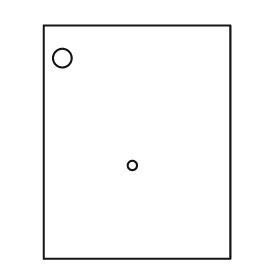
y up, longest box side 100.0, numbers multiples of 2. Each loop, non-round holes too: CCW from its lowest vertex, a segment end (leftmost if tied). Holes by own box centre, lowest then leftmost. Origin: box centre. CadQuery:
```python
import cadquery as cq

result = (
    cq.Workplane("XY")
    .moveTo(-40.0, -50.0)
    .lineTo(40.0, -50.0)
    .lineTo(40.0, 50.0)
    .lineTo(-40.0, 50.0)
    .close()
    .moveTo(-2.0, -10.0)
    .circle(2.0)
    .moveTo(-32.0, 36.0)
    .circle(4.0)
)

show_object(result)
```